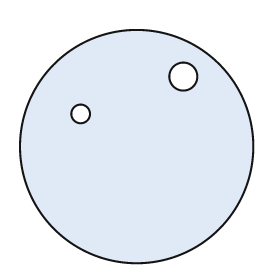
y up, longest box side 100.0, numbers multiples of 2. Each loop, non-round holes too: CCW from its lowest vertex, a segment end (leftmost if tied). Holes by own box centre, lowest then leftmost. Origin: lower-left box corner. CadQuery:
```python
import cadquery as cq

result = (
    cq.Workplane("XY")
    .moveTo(50.0, 50.0)
    .circle(50.0)
    .moveTo(26.0, 64.0)
    .circle(4.0)
    .moveTo(70.0, 80.0)
    .circle(6.0)
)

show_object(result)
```